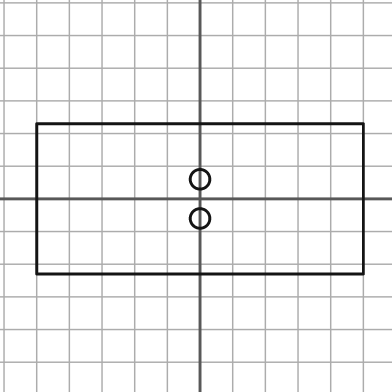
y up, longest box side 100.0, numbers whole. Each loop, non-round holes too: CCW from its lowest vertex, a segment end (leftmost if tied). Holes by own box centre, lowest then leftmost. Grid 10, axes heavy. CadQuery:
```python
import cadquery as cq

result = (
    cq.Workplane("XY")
    .moveTo(-50.0, -23.0)
    .lineTo(50.0, -23.0)
    .lineTo(50.0, 23.0)
    .lineTo(-50.0, 23.0)
    .close()
    .moveTo(0.0, -6.0)
    .circle(3.0)
    .moveTo(0.0, 6.0)
    .circle(3.0)
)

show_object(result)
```